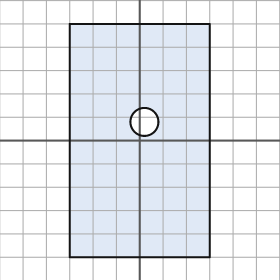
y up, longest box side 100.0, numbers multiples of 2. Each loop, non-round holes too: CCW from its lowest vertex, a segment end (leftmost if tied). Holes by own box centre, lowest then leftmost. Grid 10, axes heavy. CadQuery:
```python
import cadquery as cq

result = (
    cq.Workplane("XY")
    .moveTo(-30.0, -50.0)
    .lineTo(30.0, -50.0)
    .lineTo(30.0, 50.0)
    .lineTo(-30.0, 50.0)
    .close()
    .moveTo(2.0, 8.0)
    .circle(6.0)
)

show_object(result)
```